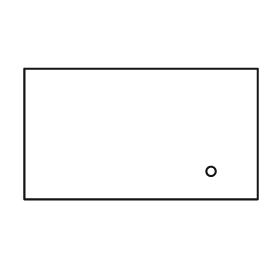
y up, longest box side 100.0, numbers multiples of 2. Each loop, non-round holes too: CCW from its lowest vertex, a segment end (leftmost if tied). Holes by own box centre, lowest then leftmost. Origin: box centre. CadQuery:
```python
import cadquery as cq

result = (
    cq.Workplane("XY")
    .moveTo(-50.0, -28.0)
    .lineTo(50.0, -28.0)
    .lineTo(50.0, 28.0)
    .lineTo(-50.0, 28.0)
    .close()
    .moveTo(30.0, -16.0)
    .circle(2.0)
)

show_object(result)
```